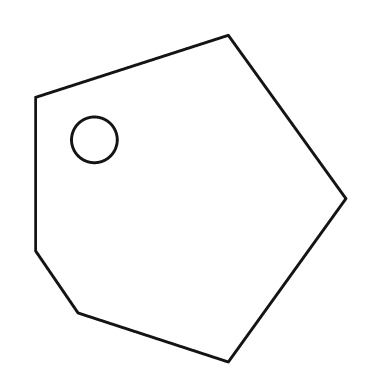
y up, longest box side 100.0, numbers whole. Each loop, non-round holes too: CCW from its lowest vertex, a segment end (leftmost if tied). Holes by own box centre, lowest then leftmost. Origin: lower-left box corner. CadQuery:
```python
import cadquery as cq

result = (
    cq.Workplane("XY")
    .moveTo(59.0, 0.0)
    .lineTo(95.0, 50.0)
    .lineTo(59.0, 100.0)
    .lineTo(0.0, 81.0)
    .lineTo(0.0, 34.0)
    .lineTo(13.0, 15.0)
    .close()
    .moveTo(18.0, 68.0)
    .circle(7.0)
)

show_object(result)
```